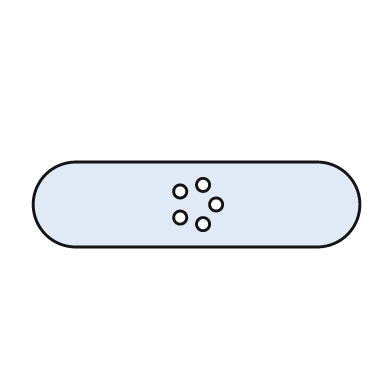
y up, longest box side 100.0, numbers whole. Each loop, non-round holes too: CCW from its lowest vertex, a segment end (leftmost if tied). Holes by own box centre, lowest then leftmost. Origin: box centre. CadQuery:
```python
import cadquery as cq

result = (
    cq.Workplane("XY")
    .moveTo(-37.0, -13.0)
    .lineTo(37.0, -13.0)
    .threePointArc((50.0, 0.0), (37.0, 13.0))
    .lineTo(-37.0, 13.0)
    .threePointArc((-50.0, 0.0), (-37.0, -13.0))
    .close()
    .moveTo(2.0, -6.0)
    .circle(2.0)
    .moveTo(-5.0, -4.0)
    .circle(2.0)
    .moveTo(6.0, 0.0)
    .circle(2.0)
    .moveTo(-5.0, 4.0)
    .circle(2.0)
    .moveTo(2.0, 6.0)
    .circle(2.0)
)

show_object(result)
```